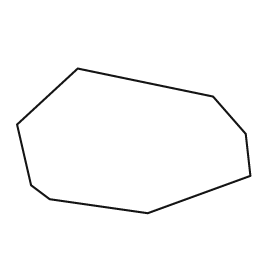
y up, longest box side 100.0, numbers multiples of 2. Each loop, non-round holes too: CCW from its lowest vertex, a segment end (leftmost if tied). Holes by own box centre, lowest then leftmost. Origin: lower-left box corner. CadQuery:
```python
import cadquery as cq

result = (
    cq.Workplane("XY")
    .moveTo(56.0, 0.0)
    .lineTo(100.0, 16.0)
    .lineTo(98.0, 34.0)
    .lineTo(84.0, 50.0)
    .lineTo(26.0, 62.0)
    .lineTo(0.0, 38.0)
    .lineTo(6.0, 12.0)
    .lineTo(14.0, 6.0)
    .close()
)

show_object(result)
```